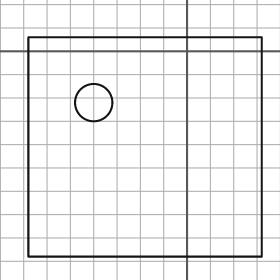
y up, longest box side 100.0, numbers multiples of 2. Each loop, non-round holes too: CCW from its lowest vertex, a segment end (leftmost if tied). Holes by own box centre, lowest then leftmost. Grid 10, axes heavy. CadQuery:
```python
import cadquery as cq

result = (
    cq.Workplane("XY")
    .moveTo(-68.0, -88.0)
    .lineTo(32.0, -88.0)
    .lineTo(32.0, 6.0)
    .lineTo(-68.0, 6.0)
    .close()
    .moveTo(-40.0, -22.0)
    .circle(8.0)
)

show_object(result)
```